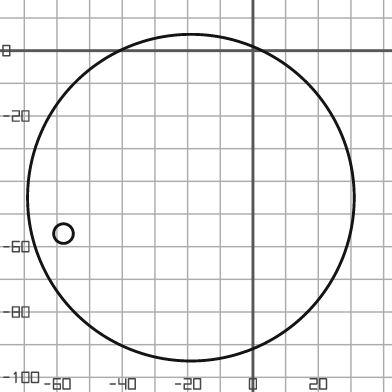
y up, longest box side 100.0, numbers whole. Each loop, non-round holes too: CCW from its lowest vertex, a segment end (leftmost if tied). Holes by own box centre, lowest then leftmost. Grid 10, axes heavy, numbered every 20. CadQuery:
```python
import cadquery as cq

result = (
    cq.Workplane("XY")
    .moveTo(-19.0, -45.0)
    .circle(50.0)
    .moveTo(-58.0, -56.0)
    .circle(3.0)
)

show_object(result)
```